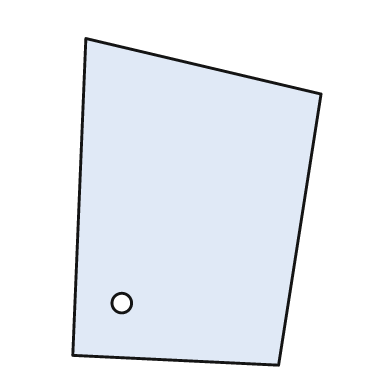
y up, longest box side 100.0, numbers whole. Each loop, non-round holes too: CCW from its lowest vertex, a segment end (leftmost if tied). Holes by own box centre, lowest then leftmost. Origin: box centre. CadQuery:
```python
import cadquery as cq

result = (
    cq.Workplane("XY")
    .moveTo(25.0, -50.0)
    .lineTo(38.0, 33.0)
    .lineTo(-34.0, 50.0)
    .lineTo(-38.0, -47.0)
    .close()
    .moveTo(-23.0, -31.0)
    .circle(3.0)
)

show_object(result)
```